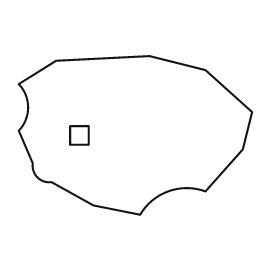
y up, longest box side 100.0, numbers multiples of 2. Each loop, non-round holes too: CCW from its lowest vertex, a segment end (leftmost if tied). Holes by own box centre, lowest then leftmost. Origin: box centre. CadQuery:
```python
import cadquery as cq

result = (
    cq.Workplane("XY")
    .moveTo(2.0, -34.0)
    .threePointArc((14.0, -24.0), (30.0, -24.0))
    .lineTo(46.0, -6.0)
    .lineTo(50.0, 10.0)
    .lineTo(30.0, 28.0)
    .lineTo(6.0, 34.0)
    .lineTo(-34.0, 32.0)
    .lineTo(-50.0, 22.0)
    .threePointArc((-46.0, 12.0), (-50.0, 2.0))
    .lineTo(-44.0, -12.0)
    .threePointArc((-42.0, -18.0), (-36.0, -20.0))
    .lineTo(-18.0, -30.0)
    .close()
    .moveTo(-28.0, -4.0)
    .lineTo(-20.0, -4.0)
    .lineTo(-20.0, 4.0)
    .lineTo(-28.0, 4.0)
    .close()
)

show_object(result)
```